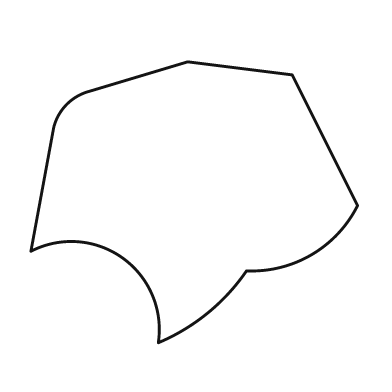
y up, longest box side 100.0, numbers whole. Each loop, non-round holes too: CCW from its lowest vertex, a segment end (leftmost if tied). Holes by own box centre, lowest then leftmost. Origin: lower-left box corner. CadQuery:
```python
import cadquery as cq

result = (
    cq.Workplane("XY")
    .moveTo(39.0, 0.0)
    .threePointArc((54.0, 9.0), (66.0, 22.0))
    .threePointArc((86.0, 27.0), (100.0, 42.0))
    .lineTo(80.0, 82.0)
    .lineTo(48.0, 86.0)
    .lineTo(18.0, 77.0)
    .threePointArc((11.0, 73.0), (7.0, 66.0))
    .lineTo(0.0, 28.0)
    .threePointArc((28.0, 26.0), (39.0, 0.0))
    .close()
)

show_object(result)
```